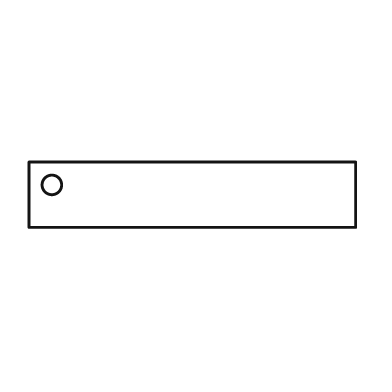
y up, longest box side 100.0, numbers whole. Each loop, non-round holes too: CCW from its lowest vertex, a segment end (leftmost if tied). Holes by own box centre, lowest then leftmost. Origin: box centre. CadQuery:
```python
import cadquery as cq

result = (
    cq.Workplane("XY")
    .moveTo(-50.0, -10.0)
    .lineTo(50.0, -10.0)
    .lineTo(50.0, 10.0)
    .lineTo(-50.0, 10.0)
    .close()
    .moveTo(-43.0, 3.0)
    .circle(3.0)
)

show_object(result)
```